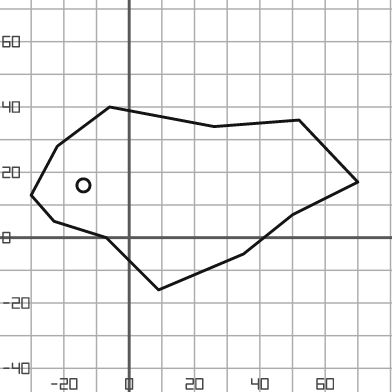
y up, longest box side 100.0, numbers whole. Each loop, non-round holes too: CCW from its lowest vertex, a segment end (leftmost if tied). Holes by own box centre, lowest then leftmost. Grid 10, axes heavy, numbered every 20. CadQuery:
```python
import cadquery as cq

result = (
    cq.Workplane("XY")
    .moveTo(9.0, -16.0)
    .lineTo(35.0, -5.0)
    .lineTo(50.0, 7.0)
    .lineTo(70.0, 17.0)
    .lineTo(52.0, 36.0)
    .lineTo(26.0, 34.0)
    .lineTo(-6.0, 40.0)
    .lineTo(-22.0, 28.0)
    .lineTo(-30.0, 13.0)
    .lineTo(-23.0, 5.0)
    .lineTo(-7.0, 0.0)
    .close()
    .moveTo(-14.0, 16.0)
    .circle(2.0)
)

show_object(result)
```